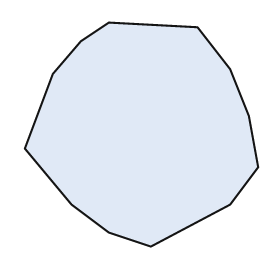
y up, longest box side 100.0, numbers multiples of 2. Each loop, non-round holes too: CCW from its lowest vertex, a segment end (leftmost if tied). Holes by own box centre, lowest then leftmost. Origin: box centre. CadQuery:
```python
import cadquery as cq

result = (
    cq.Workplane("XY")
    .moveTo(4.0, -48.0)
    .lineTo(38.0, -30.0)
    .lineTo(50.0, -14.0)
    .lineTo(46.0, 8.0)
    .lineTo(38.0, 28.0)
    .lineTo(24.0, 46.0)
    .lineTo(-14.0, 48.0)
    .lineTo(-26.0, 40.0)
    .lineTo(-38.0, 26.0)
    .lineTo(-50.0, -6.0)
    .lineTo(-30.0, -30.0)
    .lineTo(-14.0, -42.0)
    .close()
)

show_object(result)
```